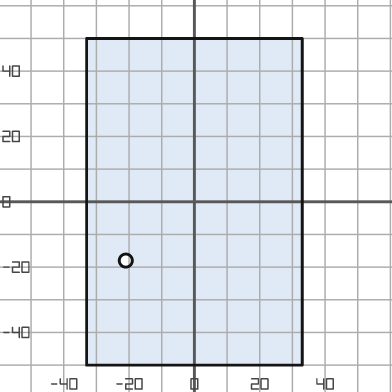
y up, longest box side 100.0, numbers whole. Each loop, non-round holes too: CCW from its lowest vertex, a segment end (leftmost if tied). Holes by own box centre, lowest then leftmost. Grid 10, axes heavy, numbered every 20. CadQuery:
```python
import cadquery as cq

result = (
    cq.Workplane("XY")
    .moveTo(-33.0, -50.0)
    .lineTo(33.0, -50.0)
    .lineTo(33.0, 50.0)
    .lineTo(-33.0, 50.0)
    .close()
    .moveTo(-21.0, -18.0)
    .circle(2.0)
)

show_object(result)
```